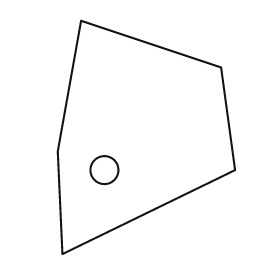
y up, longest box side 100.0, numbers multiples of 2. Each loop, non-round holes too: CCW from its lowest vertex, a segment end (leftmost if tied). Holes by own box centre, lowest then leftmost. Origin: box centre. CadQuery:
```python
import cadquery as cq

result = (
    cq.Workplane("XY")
    .moveTo(-36.0, -50.0)
    .lineTo(38.0, -14.0)
    .lineTo(32.0, 30.0)
    .lineTo(-28.0, 50.0)
    .lineTo(-38.0, -6.0)
    .close()
    .moveTo(-18.0, -14.0)
    .circle(6.0)
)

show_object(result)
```